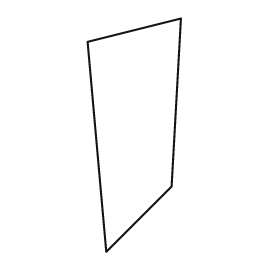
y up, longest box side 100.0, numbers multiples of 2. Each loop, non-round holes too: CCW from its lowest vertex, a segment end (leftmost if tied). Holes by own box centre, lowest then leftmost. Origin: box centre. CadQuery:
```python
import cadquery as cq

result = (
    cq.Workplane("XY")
    .moveTo(-12.0, -50.0)
    .lineTo(16.0, -22.0)
    .lineTo(20.0, 50.0)
    .lineTo(-20.0, 40.0)
    .close()
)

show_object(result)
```